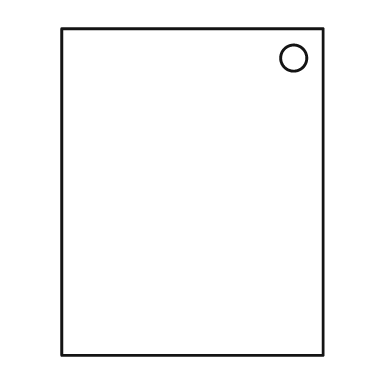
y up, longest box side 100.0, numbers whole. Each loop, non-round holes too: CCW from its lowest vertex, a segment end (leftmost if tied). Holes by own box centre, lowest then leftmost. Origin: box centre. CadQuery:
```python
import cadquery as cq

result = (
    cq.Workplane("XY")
    .moveTo(-40.0, -50.0)
    .lineTo(40.0, -50.0)
    .lineTo(40.0, 50.0)
    .lineTo(-40.0, 50.0)
    .close()
    .moveTo(31.0, 41.0)
    .circle(4.0)
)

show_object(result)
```